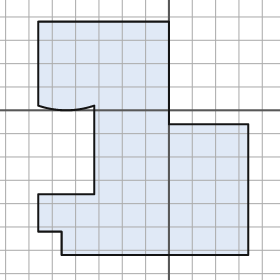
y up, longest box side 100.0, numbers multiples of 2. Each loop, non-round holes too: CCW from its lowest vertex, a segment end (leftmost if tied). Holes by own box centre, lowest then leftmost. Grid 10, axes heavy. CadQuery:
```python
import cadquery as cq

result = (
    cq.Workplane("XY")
    .moveTo(-46.0, -62.0)
    .lineTo(34.0, -62.0)
    .lineTo(34.0, -6.0)
    .lineTo(0.0, -6.0)
    .lineTo(0.0, 38.0)
    .lineTo(-56.0, 38.0)
    .lineTo(-56.0, 2.0)
    .threePointArc((-44.0, 0.0), (-32.0, 2.0))
    .lineTo(-32.0, -36.0)
    .lineTo(-56.0, -36.0)
    .lineTo(-56.0, -52.0)
    .lineTo(-46.0, -52.0)
    .close()
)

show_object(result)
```